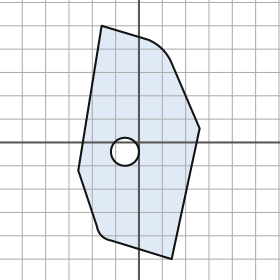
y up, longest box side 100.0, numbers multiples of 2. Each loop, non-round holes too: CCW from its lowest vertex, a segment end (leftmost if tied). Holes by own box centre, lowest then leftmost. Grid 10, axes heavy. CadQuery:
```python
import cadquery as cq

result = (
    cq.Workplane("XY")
    .moveTo(14.0, -50.0)
    .lineTo(26.0, 6.0)
    .lineTo(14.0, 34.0)
    .threePointArc((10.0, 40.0), (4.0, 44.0))
    .lineTo(-16.0, 50.0)
    .lineTo(-26.0, -12.0)
    .lineTo(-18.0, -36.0)
    .threePointArc((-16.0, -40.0), (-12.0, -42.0))
    .close()
    .moveTo(-6.0, -4.0)
    .circle(6.0)
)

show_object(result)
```